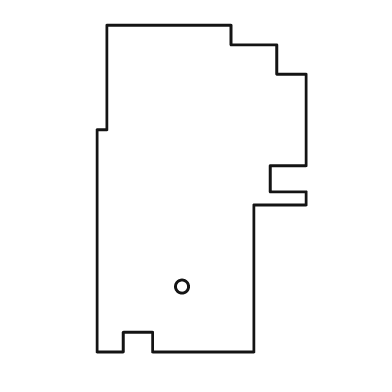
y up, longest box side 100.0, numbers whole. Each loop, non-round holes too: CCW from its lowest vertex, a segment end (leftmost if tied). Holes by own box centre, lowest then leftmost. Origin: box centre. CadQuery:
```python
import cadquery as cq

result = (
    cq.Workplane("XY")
    .moveTo(-32.0, -50.0)
    .lineTo(-24.0, -50.0)
    .lineTo(-24.0, -44.0)
    .lineTo(-15.0, -44.0)
    .lineTo(-15.0, -50.0)
    .lineTo(16.0, -50.0)
    .lineTo(16.0, -5.0)
    .lineTo(32.0, -5.0)
    .lineTo(32.0, -1.0)
    .lineTo(21.0, -1.0)
    .lineTo(21.0, 7.0)
    .lineTo(32.0, 7.0)
    .lineTo(32.0, 35.0)
    .lineTo(23.0, 35.0)
    .lineTo(23.0, 44.0)
    .lineTo(9.0, 44.0)
    .lineTo(9.0, 50.0)
    .lineTo(-29.0, 50.0)
    .lineTo(-29.0, 18.0)
    .lineTo(-32.0, 18.0)
    .close()
    .moveTo(-6.0, -30.0)
    .circle(2.0)
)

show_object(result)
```